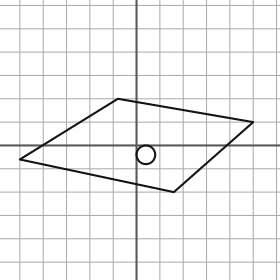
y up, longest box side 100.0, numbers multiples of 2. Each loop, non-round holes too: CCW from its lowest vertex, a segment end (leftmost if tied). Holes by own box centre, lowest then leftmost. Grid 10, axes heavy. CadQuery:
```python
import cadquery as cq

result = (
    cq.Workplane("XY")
    .moveTo(16.0, -20.0)
    .lineTo(50.0, 10.0)
    .lineTo(-8.0, 20.0)
    .lineTo(-50.0, -6.0)
    .close()
    .moveTo(4.0, -4.0)
    .circle(4.0)
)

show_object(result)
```